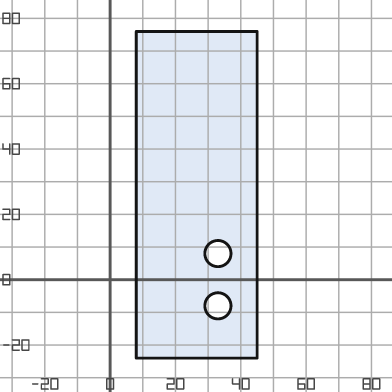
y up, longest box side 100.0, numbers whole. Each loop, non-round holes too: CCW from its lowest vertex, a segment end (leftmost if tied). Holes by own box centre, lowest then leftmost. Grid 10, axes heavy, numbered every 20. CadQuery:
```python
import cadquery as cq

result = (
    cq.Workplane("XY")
    .moveTo(8.0, -24.0)
    .lineTo(45.0, -24.0)
    .lineTo(45.0, 76.0)
    .lineTo(8.0, 76.0)
    .close()
    .moveTo(33.0, -8.0)
    .circle(4.0)
    .moveTo(33.0, 8.0)
    .circle(4.0)
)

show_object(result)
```